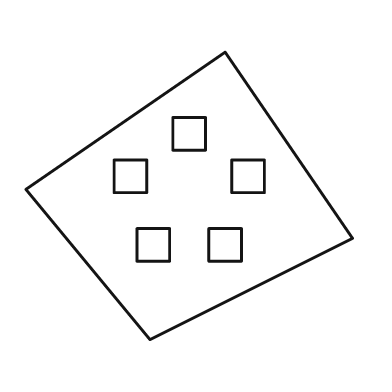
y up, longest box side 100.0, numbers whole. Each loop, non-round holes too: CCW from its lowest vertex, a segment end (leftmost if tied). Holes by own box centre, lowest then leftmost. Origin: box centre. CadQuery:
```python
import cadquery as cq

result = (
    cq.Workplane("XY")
    .moveTo(-12.0, -44.0)
    .lineTo(50.0, -13.0)
    .lineTo(11.0, 44.0)
    .lineTo(-50.0, 2.0)
    .close()
    .moveTo(-16.0, -20.0)
    .lineTo(-6.0, -20.0)
    .lineTo(-6.0, -10.0)
    .lineTo(-16.0, -10.0)
    .close()
    .moveTo(6.0, -20.0)
    .lineTo(16.0, -20.0)
    .lineTo(16.0, -10.0)
    .lineTo(6.0, -10.0)
    .close()
    .moveTo(-23.0, 1.0)
    .lineTo(-13.0, 1.0)
    .lineTo(-13.0, 11.0)
    .lineTo(-23.0, 11.0)
    .close()
    .moveTo(13.0, 1.0)
    .lineTo(23.0, 1.0)
    .lineTo(23.0, 11.0)
    .lineTo(13.0, 11.0)
    .close()
    .moveTo(-5.0, 14.0)
    .lineTo(5.0, 14.0)
    .lineTo(5.0, 24.0)
    .lineTo(-5.0, 24.0)
    .close()
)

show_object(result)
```